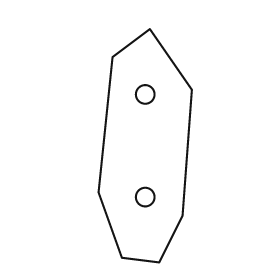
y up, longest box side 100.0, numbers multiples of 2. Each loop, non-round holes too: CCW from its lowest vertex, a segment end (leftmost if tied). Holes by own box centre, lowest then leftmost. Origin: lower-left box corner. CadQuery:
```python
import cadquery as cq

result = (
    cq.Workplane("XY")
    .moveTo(26.0, 0.0)
    .lineTo(36.0, 20.0)
    .lineTo(40.0, 74.0)
    .lineTo(22.0, 100.0)
    .lineTo(6.0, 88.0)
    .lineTo(0.0, 30.0)
    .lineTo(10.0, 2.0)
    .close()
    .moveTo(20.0, 28.0)
    .circle(4.0)
    .moveTo(20.0, 72.0)
    .circle(4.0)
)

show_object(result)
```